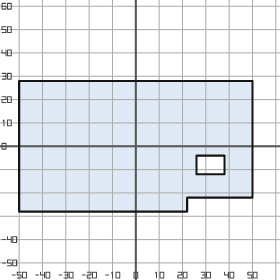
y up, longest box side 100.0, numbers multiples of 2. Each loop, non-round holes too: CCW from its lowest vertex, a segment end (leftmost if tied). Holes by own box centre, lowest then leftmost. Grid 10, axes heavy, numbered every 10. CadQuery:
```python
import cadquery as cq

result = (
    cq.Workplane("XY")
    .moveTo(-50.0, -28.0)
    .lineTo(22.0, -28.0)
    .lineTo(22.0, -22.0)
    .lineTo(50.0, -22.0)
    .lineTo(50.0, 28.0)
    .lineTo(-50.0, 28.0)
    .close()
    .moveTo(26.0, -12.0)
    .lineTo(38.0, -12.0)
    .lineTo(38.0, -4.0)
    .lineTo(26.0, -4.0)
    .close()
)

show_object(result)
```